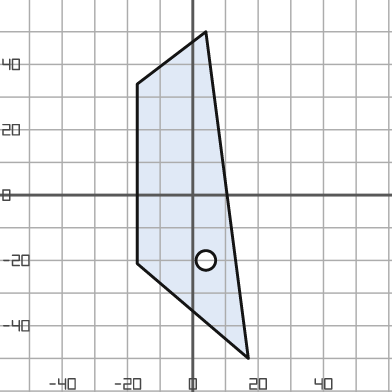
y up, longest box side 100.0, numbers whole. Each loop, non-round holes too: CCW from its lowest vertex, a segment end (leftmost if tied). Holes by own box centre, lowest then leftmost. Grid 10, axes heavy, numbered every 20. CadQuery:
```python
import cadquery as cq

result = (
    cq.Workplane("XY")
    .moveTo(17.0, -50.0)
    .lineTo(4.0, 50.0)
    .lineTo(-17.0, 34.0)
    .lineTo(-17.0, -21.0)
    .close()
    .moveTo(4.0, -20.0)
    .circle(3.0)
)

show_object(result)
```